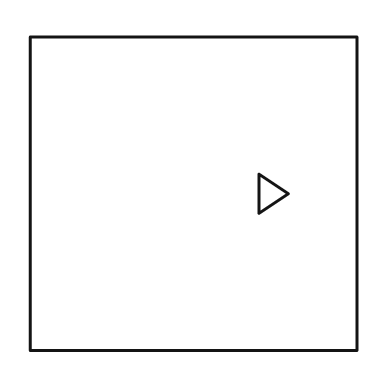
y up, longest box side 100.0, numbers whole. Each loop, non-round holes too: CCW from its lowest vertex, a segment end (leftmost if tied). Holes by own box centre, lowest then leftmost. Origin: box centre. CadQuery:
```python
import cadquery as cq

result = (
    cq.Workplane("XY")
    .moveTo(-50.0, -48.0)
    .lineTo(50.0, -48.0)
    .lineTo(50.0, 48.0)
    .lineTo(-50.0, 48.0)
    .close()
    .moveTo(20.0, -6.0)
    .lineTo(29.0, 0.0)
    .lineTo(20.0, 6.0)
    .close()
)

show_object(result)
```